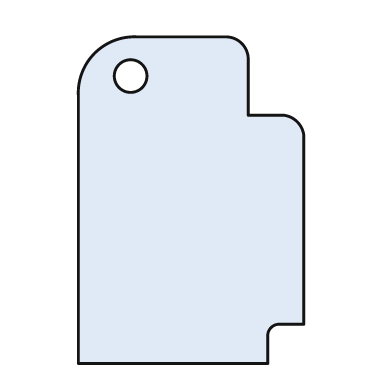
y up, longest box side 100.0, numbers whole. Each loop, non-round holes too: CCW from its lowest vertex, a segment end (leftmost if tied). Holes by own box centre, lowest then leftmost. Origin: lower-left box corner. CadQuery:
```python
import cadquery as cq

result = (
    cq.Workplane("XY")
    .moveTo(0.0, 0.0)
    .lineTo(58.0, 0.0)
    .lineTo(58.0, 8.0)
    .threePointArc((59.0, 11.0), (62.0, 12.0))
    .lineTo(69.0, 12.0)
    .lineTo(69.0, 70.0)
    .threePointArc((67.0, 74.0), (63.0, 76.0))
    .lineTo(52.0, 76.0)
    .lineTo(52.0, 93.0)
    .threePointArc((50.0, 98.0), (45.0, 100.0))
    .lineTo(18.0, 100.0)
    .threePointArc((5.0, 95.0), (0.0, 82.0))
    .close()
    .moveTo(16.0, 88.0)
    .circle(5.0)
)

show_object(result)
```